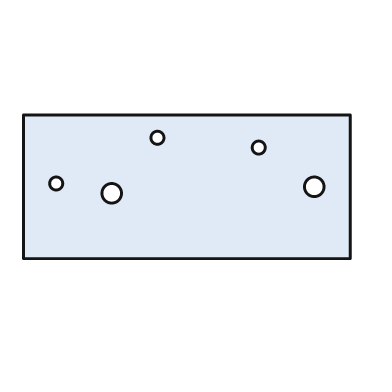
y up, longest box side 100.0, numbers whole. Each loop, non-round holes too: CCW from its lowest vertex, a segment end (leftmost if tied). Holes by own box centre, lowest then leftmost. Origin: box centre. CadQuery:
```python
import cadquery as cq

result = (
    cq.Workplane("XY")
    .moveTo(-50.0, -22.0)
    .lineTo(50.0, -22.0)
    .lineTo(50.0, 22.0)
    .lineTo(-50.0, 22.0)
    .close()
    .moveTo(-23.0, -2.0)
    .circle(3.0)
    .moveTo(39.0, 0.0)
    .circle(3.0)
    .moveTo(-40.0, 1.0)
    .circle(2.0)
    .moveTo(22.0, 12.0)
    .circle(2.0)
    .moveTo(-9.0, 15.0)
    .circle(2.0)
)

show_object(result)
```